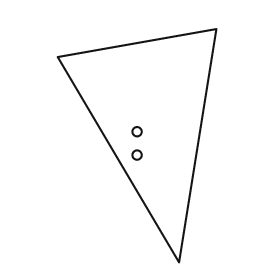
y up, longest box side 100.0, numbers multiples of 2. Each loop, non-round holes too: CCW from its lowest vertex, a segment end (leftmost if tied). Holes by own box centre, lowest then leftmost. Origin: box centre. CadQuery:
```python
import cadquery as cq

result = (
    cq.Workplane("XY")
    .moveTo(18.0, -50.0)
    .lineTo(34.0, 50.0)
    .lineTo(-34.0, 38.0)
    .close()
    .moveTo(0.0, -4.0)
    .circle(2.0)
    .moveTo(0.0, 6.0)
    .circle(2.0)
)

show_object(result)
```